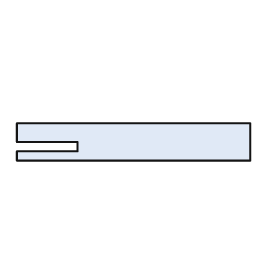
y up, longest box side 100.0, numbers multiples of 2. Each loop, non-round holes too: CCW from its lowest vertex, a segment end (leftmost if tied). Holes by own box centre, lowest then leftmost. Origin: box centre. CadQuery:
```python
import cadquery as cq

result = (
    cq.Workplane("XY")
    .moveTo(-50.0, -8.0)
    .lineTo(50.0, -8.0)
    .lineTo(50.0, 8.0)
    .lineTo(-50.0, 8.0)
    .lineTo(-50.0, 0.0)
    .lineTo(-24.0, 0.0)
    .lineTo(-24.0, -4.0)
    .lineTo(-50.0, -4.0)
    .close()
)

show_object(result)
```